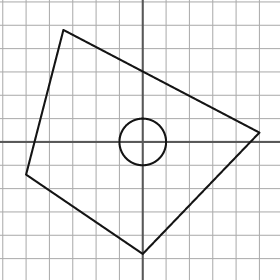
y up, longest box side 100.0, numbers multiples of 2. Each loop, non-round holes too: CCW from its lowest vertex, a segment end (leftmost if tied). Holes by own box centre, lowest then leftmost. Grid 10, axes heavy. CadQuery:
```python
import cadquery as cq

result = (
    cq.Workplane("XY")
    .moveTo(0.0, -48.0)
    .lineTo(50.0, 4.0)
    .lineTo(-34.0, 48.0)
    .lineTo(-50.0, -14.0)
    .close()
    .moveTo(0.0, 0.0)
    .circle(10.0)
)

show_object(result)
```